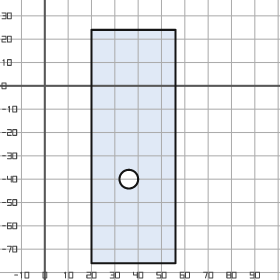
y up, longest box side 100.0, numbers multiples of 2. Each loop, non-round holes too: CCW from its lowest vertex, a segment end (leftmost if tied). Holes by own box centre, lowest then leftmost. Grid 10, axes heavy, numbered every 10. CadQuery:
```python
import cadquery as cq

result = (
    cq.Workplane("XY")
    .moveTo(20.0, -76.0)
    .lineTo(56.0, -76.0)
    .lineTo(56.0, 24.0)
    .lineTo(20.0, 24.0)
    .close()
    .moveTo(36.0, -40.0)
    .circle(4.0)
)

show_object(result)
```